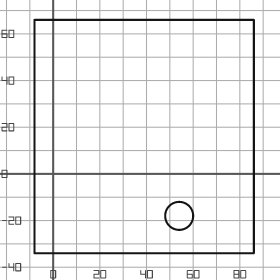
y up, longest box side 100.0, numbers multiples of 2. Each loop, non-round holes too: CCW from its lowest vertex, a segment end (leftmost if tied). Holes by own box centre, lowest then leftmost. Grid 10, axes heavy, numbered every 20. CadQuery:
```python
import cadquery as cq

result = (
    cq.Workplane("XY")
    .moveTo(-8.0, -34.0)
    .lineTo(86.0, -34.0)
    .lineTo(86.0, 66.0)
    .lineTo(-8.0, 66.0)
    .close()
    .moveTo(54.0, -18.0)
    .circle(6.0)
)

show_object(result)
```